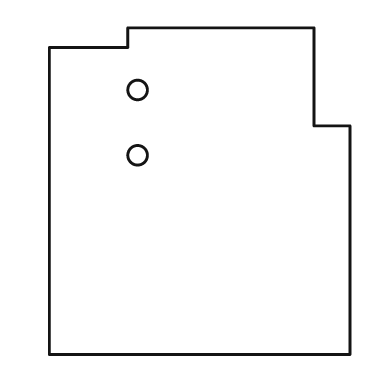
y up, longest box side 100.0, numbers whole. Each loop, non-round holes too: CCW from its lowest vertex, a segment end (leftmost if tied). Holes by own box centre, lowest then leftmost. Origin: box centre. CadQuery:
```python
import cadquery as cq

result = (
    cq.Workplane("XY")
    .moveTo(-46.0, -50.0)
    .lineTo(46.0, -50.0)
    .lineTo(46.0, 20.0)
    .lineTo(35.0, 20.0)
    .lineTo(35.0, 50.0)
    .lineTo(-22.0, 50.0)
    .lineTo(-22.0, 44.0)
    .lineTo(-46.0, 44.0)
    .close()
    .moveTo(-19.0, 11.0)
    .circle(3.0)
    .moveTo(-19.0, 31.0)
    .circle(3.0)
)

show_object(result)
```